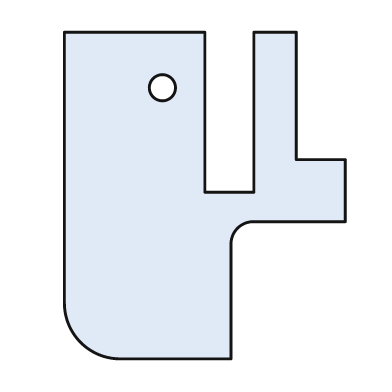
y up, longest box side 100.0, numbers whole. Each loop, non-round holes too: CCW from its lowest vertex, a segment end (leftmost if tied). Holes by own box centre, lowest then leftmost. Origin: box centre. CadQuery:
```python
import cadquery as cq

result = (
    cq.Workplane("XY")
    .moveTo(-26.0, -50.0)
    .lineTo(8.0, -50.0)
    .lineTo(8.0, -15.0)
    .threePointArc((10.0, -10.0), (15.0, -8.0))
    .lineTo(43.0, -8.0)
    .lineTo(43.0, 11.0)
    .lineTo(28.0, 11.0)
    .lineTo(28.0, 50.0)
    .lineTo(15.0, 50.0)
    .lineTo(15.0, 1.0)
    .lineTo(0.0, 1.0)
    .lineTo(0.0, 50.0)
    .lineTo(-43.0, 50.0)
    .lineTo(-43.0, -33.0)
    .threePointArc((-38.0, -45.0), (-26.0, -50.0))
    .close()
    .moveTo(-13.0, 33.0)
    .circle(4.0)
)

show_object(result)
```